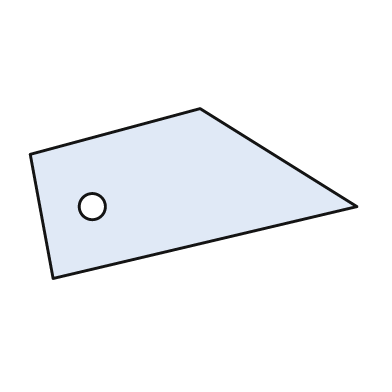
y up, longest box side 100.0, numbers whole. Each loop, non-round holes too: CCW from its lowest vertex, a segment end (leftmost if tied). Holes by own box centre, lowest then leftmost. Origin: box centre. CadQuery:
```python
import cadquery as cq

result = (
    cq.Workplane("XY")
    .moveTo(-43.0, -26.0)
    .lineTo(50.0, -4.0)
    .lineTo(2.0, 26.0)
    .lineTo(-50.0, 12.0)
    .close()
    .moveTo(-31.0, -4.0)
    .circle(4.0)
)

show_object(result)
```